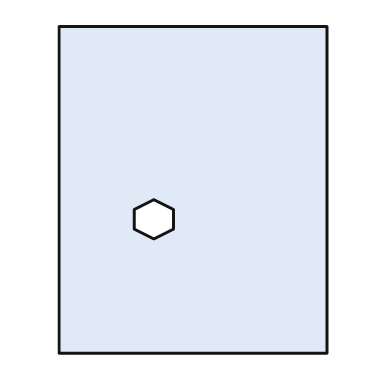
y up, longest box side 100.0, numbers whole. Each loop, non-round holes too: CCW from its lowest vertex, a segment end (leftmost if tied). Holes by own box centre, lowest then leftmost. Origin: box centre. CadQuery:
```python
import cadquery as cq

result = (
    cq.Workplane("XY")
    .moveTo(-41.0, -50.0)
    .lineTo(41.0, -50.0)
    .lineTo(41.0, 50.0)
    .lineTo(-41.0, 50.0)
    .close()
    .moveTo(-12.0, -15.0)
    .lineTo(-6.0, -12.0)
    .lineTo(-6.0, -6.0)
    .lineTo(-12.0, -3.0)
    .lineTo(-18.0, -6.0)
    .lineTo(-18.0, -12.0)
    .close()
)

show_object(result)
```